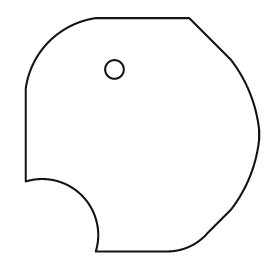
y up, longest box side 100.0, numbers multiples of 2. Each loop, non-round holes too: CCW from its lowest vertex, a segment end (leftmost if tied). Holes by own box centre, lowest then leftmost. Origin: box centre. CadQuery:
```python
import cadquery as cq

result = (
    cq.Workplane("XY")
    .moveTo(-20.0, -50.0)
    .lineTo(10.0, -50.0)
    .threePointArc((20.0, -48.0), (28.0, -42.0))
    .lineTo(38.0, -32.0)
    .threePointArc((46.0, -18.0), (50.0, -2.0))
    .lineTo(50.0, 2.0)
    .threePointArc((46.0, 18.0), (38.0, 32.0))
    .lineTo(20.0, 50.0)
    .lineTo(-20.0, 50.0)
    .threePointArc((-40.0, 40.0), (-50.0, 20.0))
    .lineTo(-50.0, -20.0)
    .threePointArc((-26.0, -26.0), (-20.0, -50.0))
    .close()
    .moveTo(-12.0, 28.0)
    .circle(4.0)
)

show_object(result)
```